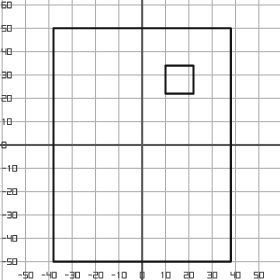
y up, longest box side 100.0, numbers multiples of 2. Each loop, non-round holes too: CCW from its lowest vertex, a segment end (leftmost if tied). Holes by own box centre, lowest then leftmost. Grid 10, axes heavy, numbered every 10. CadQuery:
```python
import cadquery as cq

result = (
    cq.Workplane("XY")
    .moveTo(-38.0, -50.0)
    .lineTo(38.0, -50.0)
    .lineTo(38.0, 50.0)
    .lineTo(-38.0, 50.0)
    .close()
    .moveTo(10.0, 22.0)
    .lineTo(22.0, 22.0)
    .lineTo(22.0, 34.0)
    .lineTo(10.0, 34.0)
    .close()
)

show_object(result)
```